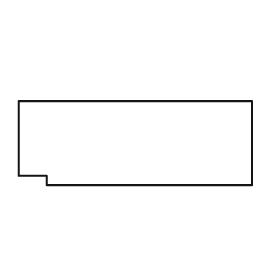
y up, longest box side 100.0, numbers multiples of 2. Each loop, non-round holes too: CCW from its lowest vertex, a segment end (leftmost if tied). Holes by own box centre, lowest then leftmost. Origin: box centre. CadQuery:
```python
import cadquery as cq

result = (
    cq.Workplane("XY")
    .moveTo(-38.0, -18.0)
    .lineTo(50.0, -18.0)
    .lineTo(50.0, 18.0)
    .lineTo(-50.0, 18.0)
    .lineTo(-50.0, -14.0)
    .lineTo(-38.0, -14.0)
    .close()
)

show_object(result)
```